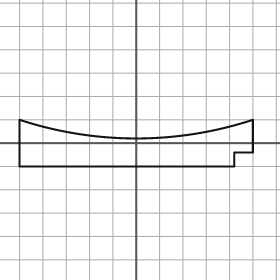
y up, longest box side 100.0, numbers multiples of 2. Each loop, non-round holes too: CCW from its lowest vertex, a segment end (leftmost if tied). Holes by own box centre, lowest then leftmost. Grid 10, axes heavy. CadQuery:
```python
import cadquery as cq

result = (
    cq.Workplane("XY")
    .moveTo(-50.0, -10.0)
    .lineTo(42.0, -10.0)
    .lineTo(42.0, -4.0)
    .lineTo(50.0, -4.0)
    .lineTo(50.0, 10.0)
    .threePointArc((0.0, 2.0), (-50.0, 10.0))
    .close()
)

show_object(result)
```